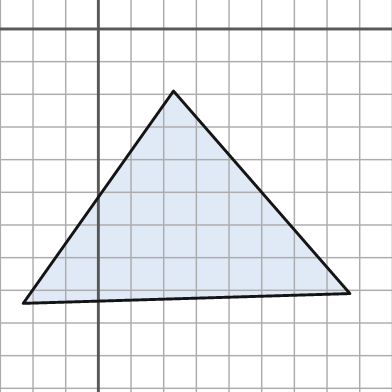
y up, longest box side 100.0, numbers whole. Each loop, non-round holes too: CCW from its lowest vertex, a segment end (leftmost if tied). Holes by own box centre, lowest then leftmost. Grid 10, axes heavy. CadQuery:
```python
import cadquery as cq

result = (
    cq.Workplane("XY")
    .moveTo(-23.0, -84.0)
    .lineTo(77.0, -81.0)
    .lineTo(23.0, -19.0)
    .close()
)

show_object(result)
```